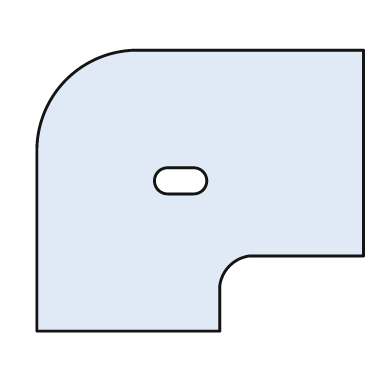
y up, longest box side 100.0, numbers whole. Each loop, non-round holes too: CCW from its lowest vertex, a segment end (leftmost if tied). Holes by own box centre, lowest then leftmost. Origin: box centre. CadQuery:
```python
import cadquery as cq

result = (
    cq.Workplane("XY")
    .moveTo(-50.0, -43.0)
    .lineTo(6.0, -43.0)
    .lineTo(6.0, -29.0)
    .threePointArc((9.0, -23.0), (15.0, -20.0))
    .lineTo(50.0, -20.0)
    .lineTo(50.0, 43.0)
    .lineTo(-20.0, 43.0)
    .threePointArc((-41.0, 34.0), (-50.0, 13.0))
    .close()
    .moveTo(-10.0, -1.0)
    .lineTo(-2.0, -1.0)
    .threePointArc((2.0, 3.0), (-2.0, 7.0))
    .lineTo(-10.0, 7.0)
    .threePointArc((-14.0, 3.0), (-10.0, -1.0))
    .close()
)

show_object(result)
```